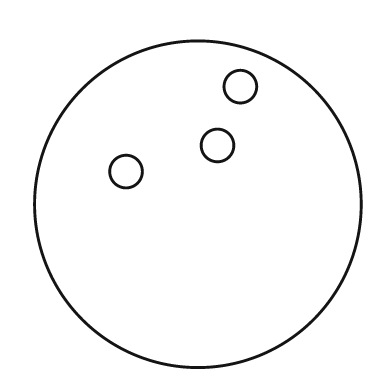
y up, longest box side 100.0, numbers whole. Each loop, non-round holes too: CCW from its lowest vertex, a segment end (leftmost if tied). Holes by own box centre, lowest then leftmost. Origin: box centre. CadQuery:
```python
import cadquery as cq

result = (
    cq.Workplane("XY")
    .moveTo(0.0, 0.0)
    .circle(50.0)
    .moveTo(-22.0, 10.0)
    .circle(5.0)
    .moveTo(6.0, 18.0)
    .circle(5.0)
    .moveTo(13.0, 36.0)
    .circle(5.0)
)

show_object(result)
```